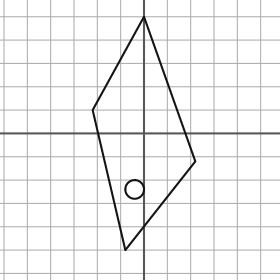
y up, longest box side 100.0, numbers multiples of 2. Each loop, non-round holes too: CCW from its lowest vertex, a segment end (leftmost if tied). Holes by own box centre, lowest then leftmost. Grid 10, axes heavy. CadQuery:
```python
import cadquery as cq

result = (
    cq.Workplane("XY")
    .moveTo(-8.0, -50.0)
    .lineTo(22.0, -12.0)
    .lineTo(0.0, 50.0)
    .lineTo(-22.0, 10.0)
    .close()
    .moveTo(-4.0, -24.0)
    .circle(4.0)
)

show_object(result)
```